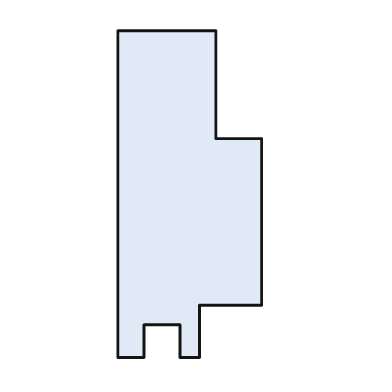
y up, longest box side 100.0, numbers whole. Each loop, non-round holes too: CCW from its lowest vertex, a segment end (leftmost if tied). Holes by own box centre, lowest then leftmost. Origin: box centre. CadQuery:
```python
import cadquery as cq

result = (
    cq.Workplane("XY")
    .moveTo(-22.0, -50.0)
    .lineTo(-14.0, -50.0)
    .lineTo(-14.0, -40.0)
    .lineTo(-3.0, -40.0)
    .lineTo(-3.0, -50.0)
    .lineTo(3.0, -50.0)
    .lineTo(3.0, -34.0)
    .lineTo(22.0, -34.0)
    .lineTo(22.0, 17.0)
    .lineTo(8.0, 17.0)
    .lineTo(8.0, 50.0)
    .lineTo(-22.0, 50.0)
    .close()
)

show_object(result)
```